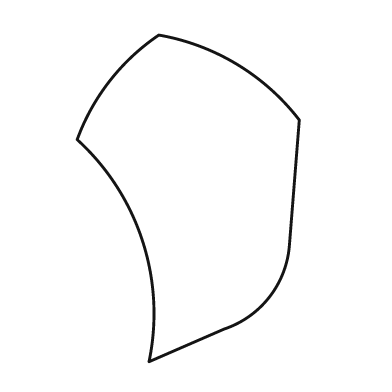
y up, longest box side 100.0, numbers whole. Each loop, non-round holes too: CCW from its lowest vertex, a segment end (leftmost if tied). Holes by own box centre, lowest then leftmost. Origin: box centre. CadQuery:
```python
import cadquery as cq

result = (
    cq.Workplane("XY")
    .moveTo(-12.0, -50.0)
    .lineTo(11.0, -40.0)
    .threePointArc((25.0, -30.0), (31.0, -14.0))
    .lineTo(34.0, 24.0)
    .threePointArc((15.0, 41.0), (-9.0, 50.0))
    .threePointArc((-24.0, 36.0), (-34.0, 18.0))
    .threePointArc((-14.0, -13.0), (-12.0, -50.0))
    .close()
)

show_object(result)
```